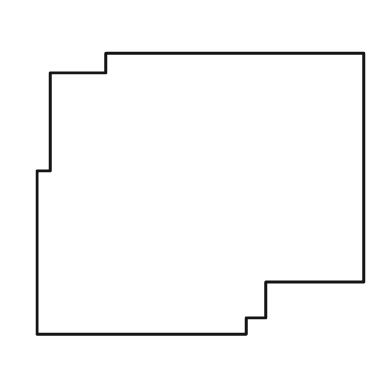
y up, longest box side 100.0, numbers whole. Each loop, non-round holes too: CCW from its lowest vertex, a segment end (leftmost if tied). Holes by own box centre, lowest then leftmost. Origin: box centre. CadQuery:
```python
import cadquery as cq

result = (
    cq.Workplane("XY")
    .moveTo(-50.0, -43.0)
    .lineTo(14.0, -43.0)
    .lineTo(14.0, -38.0)
    .lineTo(20.0, -38.0)
    .lineTo(20.0, -27.0)
    .lineTo(50.0, -27.0)
    .lineTo(50.0, 43.0)
    .lineTo(-29.0, 43.0)
    .lineTo(-29.0, 37.0)
    .lineTo(-46.0, 37.0)
    .lineTo(-46.0, 7.0)
    .lineTo(-50.0, 7.0)
    .close()
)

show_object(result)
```